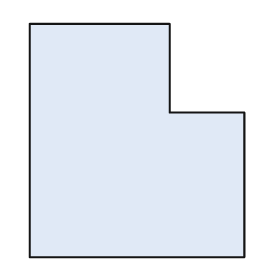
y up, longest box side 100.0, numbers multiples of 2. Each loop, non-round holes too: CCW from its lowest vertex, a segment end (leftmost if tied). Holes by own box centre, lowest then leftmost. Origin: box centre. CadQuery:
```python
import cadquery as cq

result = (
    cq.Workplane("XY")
    .moveTo(-46.0, -50.0)
    .lineTo(46.0, -50.0)
    .lineTo(46.0, 12.0)
    .lineTo(14.0, 12.0)
    .lineTo(14.0, 50.0)
    .lineTo(-46.0, 50.0)
    .close()
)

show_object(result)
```